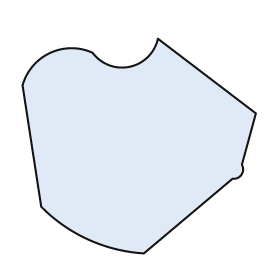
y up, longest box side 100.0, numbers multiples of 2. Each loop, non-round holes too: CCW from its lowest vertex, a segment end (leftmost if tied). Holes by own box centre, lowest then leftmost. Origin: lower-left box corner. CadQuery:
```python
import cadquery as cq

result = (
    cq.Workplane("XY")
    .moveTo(52.0, 0.0)
    .lineTo(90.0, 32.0)
    .threePointArc((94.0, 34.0), (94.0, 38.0))
    .lineTo(100.0, 60.0)
    .lineTo(58.0, 92.0)
    .threePointArc((46.0, 80.0), (30.0, 86.0))
    .threePointArc((12.0, 86.0), (0.0, 72.0))
    .lineTo(8.0, 20.0)
    .threePointArc((28.0, 6.0), (52.0, 0.0))
    .close()
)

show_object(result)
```